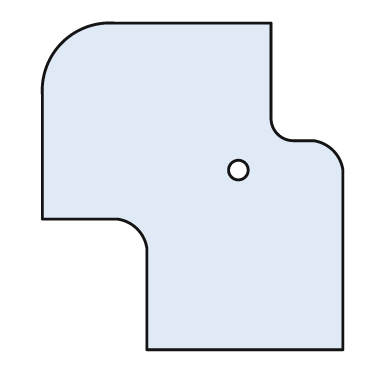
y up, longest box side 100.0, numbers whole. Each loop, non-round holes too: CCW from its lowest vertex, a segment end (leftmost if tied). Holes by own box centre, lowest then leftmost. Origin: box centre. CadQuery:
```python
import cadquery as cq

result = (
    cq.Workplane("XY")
    .moveTo(-14.0, -50.0)
    .lineTo(46.0, -50.0)
    .lineTo(46.0, 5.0)
    .threePointArc((43.0, 11.0), (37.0, 14.0))
    .lineTo(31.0, 14.0)
    .threePointArc((26.0, 16.0), (24.0, 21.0))
    .lineTo(24.0, 50.0)
    .lineTo(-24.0, 50.0)
    .threePointArc((-40.0, 44.0), (-46.0, 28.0))
    .lineTo(-46.0, -10.0)
    .lineTo(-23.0, -10.0)
    .threePointArc((-17.0, -13.0), (-14.0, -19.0))
    .close()
    .moveTo(14.0, 5.0)
    .circle(3.0)
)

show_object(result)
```